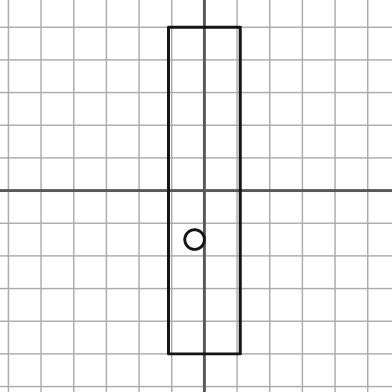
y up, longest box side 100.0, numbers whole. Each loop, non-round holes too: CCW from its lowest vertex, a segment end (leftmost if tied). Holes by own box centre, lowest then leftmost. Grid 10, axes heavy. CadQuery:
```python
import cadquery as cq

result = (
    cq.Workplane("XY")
    .moveTo(-11.0, -50.0)
    .lineTo(11.0, -50.0)
    .lineTo(11.0, 50.0)
    .lineTo(-11.0, 50.0)
    .close()
    .moveTo(-3.0, -15.0)
    .circle(3.0)
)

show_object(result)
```